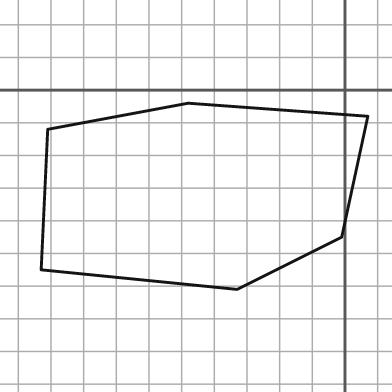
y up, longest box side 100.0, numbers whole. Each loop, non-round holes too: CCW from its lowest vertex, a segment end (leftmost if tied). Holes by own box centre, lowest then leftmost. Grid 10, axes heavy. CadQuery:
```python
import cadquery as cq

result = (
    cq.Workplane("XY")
    .moveTo(-33.0, -61.0)
    .lineTo(-1.0, -45.0)
    .lineTo(7.0, -8.0)
    .lineTo(-48.0, -4.0)
    .lineTo(-91.0, -12.0)
    .lineTo(-93.0, -55.0)
    .close()
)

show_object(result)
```